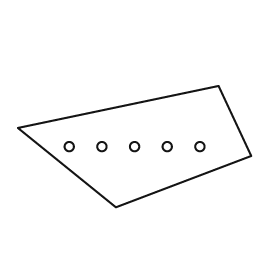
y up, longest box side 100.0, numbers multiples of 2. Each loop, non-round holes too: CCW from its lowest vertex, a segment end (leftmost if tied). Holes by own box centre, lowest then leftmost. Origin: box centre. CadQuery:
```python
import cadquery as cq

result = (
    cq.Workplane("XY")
    .moveTo(-8.0, -26.0)
    .lineTo(50.0, -4.0)
    .lineTo(36.0, 26.0)
    .lineTo(-50.0, 8.0)
    .close()
    .moveTo(-28.0, 0.0)
    .circle(2.0)
    .moveTo(-14.0, 0.0)
    .circle(2.0)
    .moveTo(0.0, 0.0)
    .circle(2.0)
    .moveTo(14.0, 0.0)
    .circle(2.0)
    .moveTo(28.0, 0.0)
    .circle(2.0)
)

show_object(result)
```